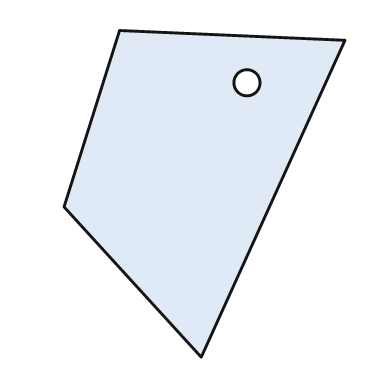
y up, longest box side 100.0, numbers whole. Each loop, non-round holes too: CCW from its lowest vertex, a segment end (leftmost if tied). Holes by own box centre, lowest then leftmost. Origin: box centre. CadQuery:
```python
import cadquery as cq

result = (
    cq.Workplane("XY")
    .moveTo(-1.0, -50.0)
    .lineTo(43.0, 47.0)
    .lineTo(-26.0, 50.0)
    .lineTo(-43.0, -4.0)
    .close()
    .moveTo(13.0, 34.0)
    .circle(4.0)
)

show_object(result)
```